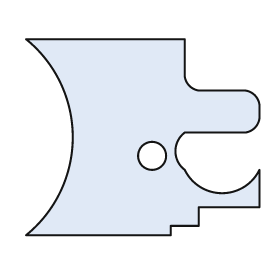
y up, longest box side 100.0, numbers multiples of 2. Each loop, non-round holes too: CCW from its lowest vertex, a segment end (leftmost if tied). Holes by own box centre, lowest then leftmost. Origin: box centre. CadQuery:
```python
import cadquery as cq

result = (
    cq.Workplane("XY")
    .moveTo(-50.0, -42.0)
    .lineTo(12.0, -42.0)
    .lineTo(12.0, -38.0)
    .lineTo(24.0, -38.0)
    .lineTo(24.0, -30.0)
    .lineTo(50.0, -30.0)
    .lineTo(50.0, -14.0)
    .threePointArc((34.0, -24.0), (18.0, -14.0))
    .threePointArc((14.0, -6.0), (18.0, 2.0))
    .lineTo(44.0, 2.0)
    .threePointArc((48.0, 4.0), (50.0, 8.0))
    .lineTo(50.0, 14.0)
    .threePointArc((48.0, 18.0), (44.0, 20.0))
    .lineTo(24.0, 20.0)
    .threePointArc((20.0, 22.0), (18.0, 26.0))
    .lineTo(18.0, 42.0)
    .lineTo(-50.0, 42.0)
    .threePointArc((-30.0, 0.0), (-50.0, -42.0))
    .close()
    .moveTo(4.0, -8.0)
    .circle(6.0)
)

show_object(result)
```